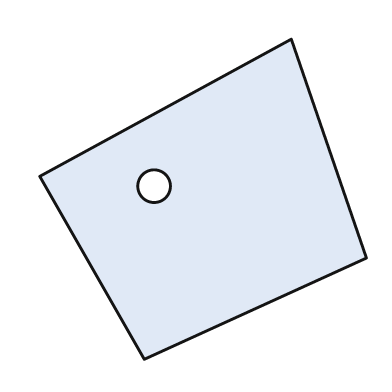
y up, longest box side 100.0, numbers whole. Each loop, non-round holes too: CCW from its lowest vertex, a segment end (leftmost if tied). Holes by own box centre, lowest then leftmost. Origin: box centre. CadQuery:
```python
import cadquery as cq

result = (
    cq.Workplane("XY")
    .moveTo(-18.0, -49.0)
    .lineTo(50.0, -18.0)
    .lineTo(27.0, 49.0)
    .lineTo(-50.0, 7.0)
    .close()
    .moveTo(-15.0, 4.0)
    .circle(5.0)
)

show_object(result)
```